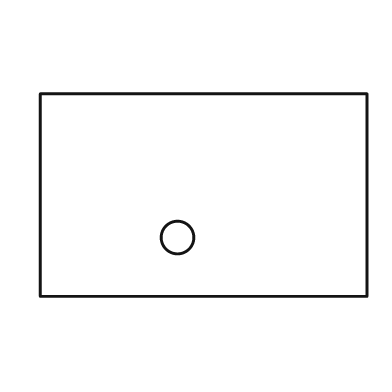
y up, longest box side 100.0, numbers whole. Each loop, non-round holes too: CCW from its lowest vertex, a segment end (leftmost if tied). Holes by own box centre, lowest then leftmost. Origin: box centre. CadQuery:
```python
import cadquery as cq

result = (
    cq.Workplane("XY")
    .moveTo(-50.0, -31.0)
    .lineTo(50.0, -31.0)
    .lineTo(50.0, 31.0)
    .lineTo(-50.0, 31.0)
    .close()
    .moveTo(-8.0, -13.0)
    .circle(5.0)
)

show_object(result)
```